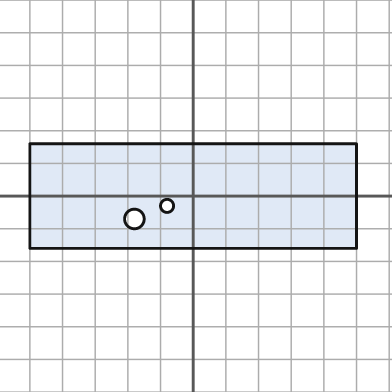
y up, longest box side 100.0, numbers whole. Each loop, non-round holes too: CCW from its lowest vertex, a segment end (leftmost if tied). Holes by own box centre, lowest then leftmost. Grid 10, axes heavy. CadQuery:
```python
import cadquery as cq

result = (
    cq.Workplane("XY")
    .moveTo(-50.0, -16.0)
    .lineTo(50.0, -16.0)
    .lineTo(50.0, 16.0)
    .lineTo(-50.0, 16.0)
    .close()
    .moveTo(-18.0, -7.0)
    .circle(3.0)
    .moveTo(-8.0, -3.0)
    .circle(2.0)
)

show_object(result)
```